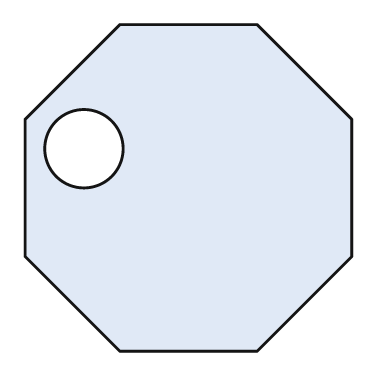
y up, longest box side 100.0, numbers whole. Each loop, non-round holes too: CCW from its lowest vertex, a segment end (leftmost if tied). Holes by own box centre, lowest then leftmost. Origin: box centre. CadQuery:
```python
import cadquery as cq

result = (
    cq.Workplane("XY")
    .moveTo(-21.0, -50.0)
    .lineTo(21.0, -50.0)
    .lineTo(50.0, -21.0)
    .lineTo(50.0, 21.0)
    .lineTo(21.0, 50.0)
    .lineTo(-21.0, 50.0)
    .lineTo(-50.0, 21.0)
    .lineTo(-50.0, -21.0)
    .close()
    .moveTo(-32.0, 12.0)
    .circle(12.0)
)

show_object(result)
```